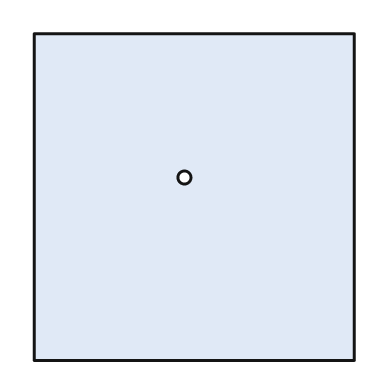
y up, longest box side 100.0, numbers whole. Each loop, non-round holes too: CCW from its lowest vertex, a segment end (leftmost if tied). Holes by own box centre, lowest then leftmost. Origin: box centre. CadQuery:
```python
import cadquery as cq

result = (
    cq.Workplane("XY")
    .moveTo(-49.0, -50.0)
    .lineTo(49.0, -50.0)
    .lineTo(49.0, 50.0)
    .lineTo(-49.0, 50.0)
    .close()
    .moveTo(-3.0, 6.0)
    .circle(2.0)
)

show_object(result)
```